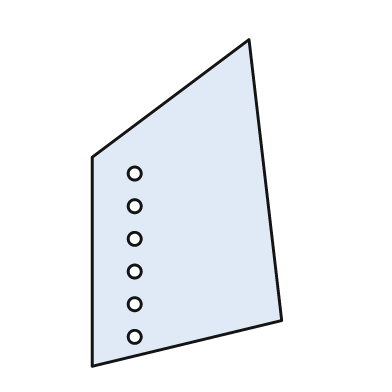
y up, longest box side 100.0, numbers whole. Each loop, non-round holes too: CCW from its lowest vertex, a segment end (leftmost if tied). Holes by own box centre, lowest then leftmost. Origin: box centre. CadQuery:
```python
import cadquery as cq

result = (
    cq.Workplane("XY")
    .moveTo(-29.0, -50.0)
    .lineTo(29.0, -36.0)
    .lineTo(19.0, 50.0)
    .lineTo(-29.0, 14.0)
    .close()
    .moveTo(-16.0, -41.0)
    .circle(2.0)
    .moveTo(-16.0, -31.0)
    .circle(2.0)
    .moveTo(-16.0, -21.0)
    .circle(2.0)
    .moveTo(-16.0, -11.0)
    .circle(2.0)
    .moveTo(-16.0, -1.0)
    .circle(2.0)
    .moveTo(-16.0, 9.0)
    .circle(2.0)
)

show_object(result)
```